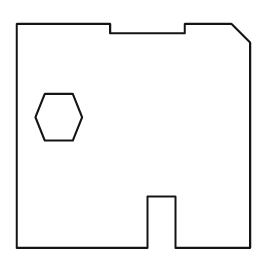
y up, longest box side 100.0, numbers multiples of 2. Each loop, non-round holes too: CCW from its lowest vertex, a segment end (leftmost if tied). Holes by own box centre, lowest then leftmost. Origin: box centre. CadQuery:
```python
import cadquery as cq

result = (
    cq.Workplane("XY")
    .moveTo(-50.0, -48.0)
    .lineTo(6.0, -48.0)
    .lineTo(6.0, -26.0)
    .lineTo(18.0, -26.0)
    .lineTo(18.0, -48.0)
    .lineTo(50.0, -48.0)
    .lineTo(50.0, 40.0)
    .lineTo(42.0, 48.0)
    .lineTo(22.0, 48.0)
    .lineTo(22.0, 44.0)
    .lineTo(-10.0, 44.0)
    .lineTo(-10.0, 48.0)
    .lineTo(-50.0, 48.0)
    .close()
    .moveTo(-38.0, -2.0)
    .lineTo(-26.0, -2.0)
    .lineTo(-22.0, 8.0)
    .lineTo(-26.0, 18.0)
    .lineTo(-38.0, 18.0)
    .lineTo(-42.0, 8.0)
    .close()
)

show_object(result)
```